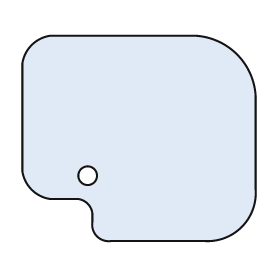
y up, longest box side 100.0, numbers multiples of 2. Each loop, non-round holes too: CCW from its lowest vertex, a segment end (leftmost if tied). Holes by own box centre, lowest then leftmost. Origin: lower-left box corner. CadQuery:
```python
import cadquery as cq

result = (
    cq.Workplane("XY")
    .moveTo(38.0, 0.0)
    .lineTo(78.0, 0.0)
    .threePointArc((94.0, 6.0), (100.0, 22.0))
    .lineTo(100.0, 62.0)
    .threePointArc((92.0, 80.0), (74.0, 88.0))
    .lineTo(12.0, 88.0)
    .threePointArc((4.0, 84.0), (0.0, 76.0))
    .lineTo(0.0, 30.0)
    .threePointArc((4.0, 22.0), (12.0, 18.0))
    .lineTo(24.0, 18.0)
    .threePointArc((28.0, 16.0), (30.0, 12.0))
    .lineTo(30.0, 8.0)
    .threePointArc((32.0, 2.0), (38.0, 0.0))
    .close()
    .moveTo(28.0, 28.0)
    .circle(4.0)
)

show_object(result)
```